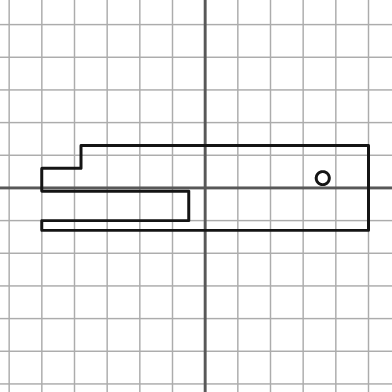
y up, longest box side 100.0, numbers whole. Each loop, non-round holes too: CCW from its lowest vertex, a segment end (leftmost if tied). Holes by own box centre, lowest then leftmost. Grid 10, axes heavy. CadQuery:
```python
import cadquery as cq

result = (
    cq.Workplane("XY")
    .moveTo(-50.0, -13.0)
    .lineTo(50.0, -13.0)
    .lineTo(50.0, 13.0)
    .lineTo(-38.0, 13.0)
    .lineTo(-38.0, 6.0)
    .lineTo(-50.0, 6.0)
    .lineTo(-50.0, -1.0)
    .lineTo(-5.0, -1.0)
    .lineTo(-5.0, -10.0)
    .lineTo(-50.0, -10.0)
    .close()
    .moveTo(36.0, 3.0)
    .circle(2.0)
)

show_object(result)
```